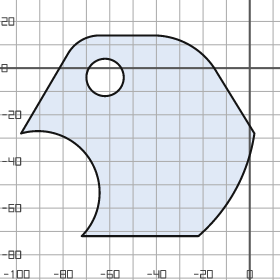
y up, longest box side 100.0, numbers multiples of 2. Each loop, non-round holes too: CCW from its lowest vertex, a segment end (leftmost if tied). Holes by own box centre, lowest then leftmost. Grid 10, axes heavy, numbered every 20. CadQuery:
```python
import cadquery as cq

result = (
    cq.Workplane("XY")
    .moveTo(-72.0, -72.0)
    .lineTo(-22.0, -72.0)
    .threePointArc((-6.0, -52.0), (2.0, -28.0))
    .lineTo(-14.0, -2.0)
    .threePointArc((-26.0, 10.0), (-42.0, 14.0))
    .lineTo(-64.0, 14.0)
    .threePointArc((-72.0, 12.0), (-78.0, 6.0))
    .lineTo(-98.0, -28.0)
    .threePointArc((-68.0, -40.0), (-72.0, -72.0))
    .close()
    .moveTo(-62.0, -4.0)
    .circle(8.0)
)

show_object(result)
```